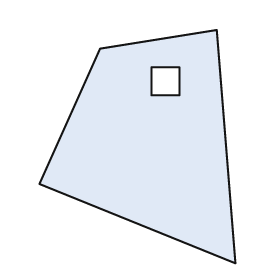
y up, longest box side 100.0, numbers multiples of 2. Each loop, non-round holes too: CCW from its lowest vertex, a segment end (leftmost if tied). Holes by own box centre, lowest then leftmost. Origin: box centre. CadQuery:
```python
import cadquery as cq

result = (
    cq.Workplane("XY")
    .moveTo(42.0, -50.0)
    .lineTo(34.0, 50.0)
    .lineTo(-16.0, 42.0)
    .lineTo(-42.0, -16.0)
    .close()
    .moveTo(6.0, 22.0)
    .lineTo(18.0, 22.0)
    .lineTo(18.0, 34.0)
    .lineTo(6.0, 34.0)
    .close()
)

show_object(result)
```